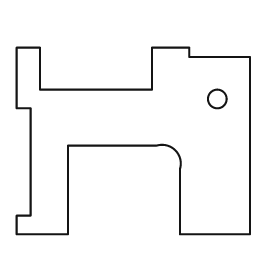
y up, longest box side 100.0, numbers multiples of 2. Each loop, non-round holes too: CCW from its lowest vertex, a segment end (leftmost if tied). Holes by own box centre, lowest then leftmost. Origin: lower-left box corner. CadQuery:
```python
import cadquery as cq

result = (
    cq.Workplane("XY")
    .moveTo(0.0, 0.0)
    .lineTo(22.0, 0.0)
    .lineTo(22.0, 38.0)
    .lineTo(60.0, 38.0)
    .threePointArc((68.0, 36.0), (70.0, 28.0))
    .lineTo(70.0, 0.0)
    .lineTo(100.0, 0.0)
    .lineTo(100.0, 76.0)
    .lineTo(74.0, 76.0)
    .lineTo(74.0, 80.0)
    .lineTo(58.0, 80.0)
    .lineTo(58.0, 62.0)
    .lineTo(10.0, 62.0)
    .lineTo(10.0, 80.0)
    .lineTo(0.0, 80.0)
    .lineTo(0.0, 54.0)
    .lineTo(6.0, 54.0)
    .lineTo(6.0, 8.0)
    .lineTo(0.0, 8.0)
    .close()
    .moveTo(86.0, 58.0)
    .circle(4.0)
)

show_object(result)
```